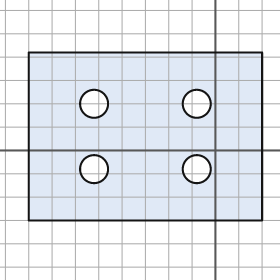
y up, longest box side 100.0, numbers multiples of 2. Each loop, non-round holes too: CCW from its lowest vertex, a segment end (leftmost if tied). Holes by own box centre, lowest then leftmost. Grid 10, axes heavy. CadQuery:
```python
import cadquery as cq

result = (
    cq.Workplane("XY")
    .moveTo(-80.0, -30.0)
    .lineTo(20.0, -30.0)
    .lineTo(20.0, 42.0)
    .lineTo(-80.0, 42.0)
    .close()
    .moveTo(-52.0, -8.0)
    .circle(6.0)
    .moveTo(-8.0, -8.0)
    .circle(6.0)
    .moveTo(-52.0, 20.0)
    .circle(6.0)
    .moveTo(-8.0, 20.0)
    .circle(6.0)
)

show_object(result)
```